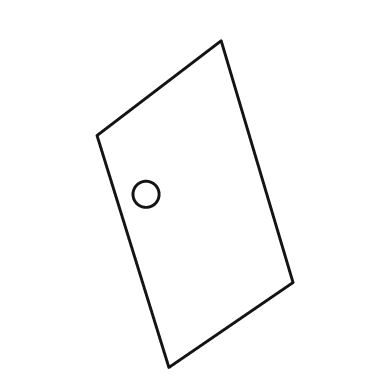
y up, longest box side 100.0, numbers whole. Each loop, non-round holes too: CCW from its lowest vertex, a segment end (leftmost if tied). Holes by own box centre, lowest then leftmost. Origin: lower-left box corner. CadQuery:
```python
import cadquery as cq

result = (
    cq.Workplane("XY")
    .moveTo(22.0, 0.0)
    .lineTo(60.0, 26.0)
    .lineTo(38.0, 100.0)
    .lineTo(0.0, 71.0)
    .close()
    .moveTo(15.0, 53.0)
    .circle(4.0)
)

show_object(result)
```